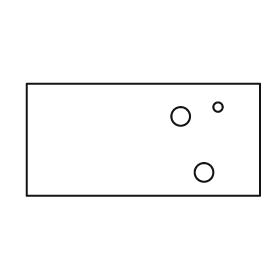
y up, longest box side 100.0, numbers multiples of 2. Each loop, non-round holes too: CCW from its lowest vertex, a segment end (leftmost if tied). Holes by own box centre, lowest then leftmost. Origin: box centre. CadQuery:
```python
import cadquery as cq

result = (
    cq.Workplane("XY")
    .moveTo(-50.0, -24.0)
    .lineTo(50.0, -24.0)
    .lineTo(50.0, 24.0)
    .lineTo(-50.0, 24.0)
    .close()
    .moveTo(26.0, -14.0)
    .circle(4.0)
    .moveTo(16.0, 10.0)
    .circle(4.0)
    .moveTo(32.0, 14.0)
    .circle(2.0)
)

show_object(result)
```